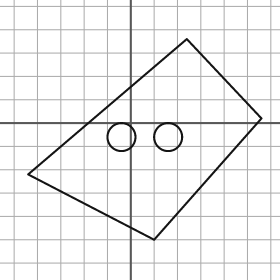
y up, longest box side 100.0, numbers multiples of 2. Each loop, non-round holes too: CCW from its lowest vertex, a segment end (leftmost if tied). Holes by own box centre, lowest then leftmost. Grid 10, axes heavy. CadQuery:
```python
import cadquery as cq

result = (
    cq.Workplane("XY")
    .moveTo(10.0, -50.0)
    .lineTo(56.0, 2.0)
    .lineTo(24.0, 36.0)
    .lineTo(-44.0, -22.0)
    .close()
    .moveTo(-4.0, -6.0)
    .circle(6.0)
    .moveTo(16.0, -6.0)
    .circle(6.0)
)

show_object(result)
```